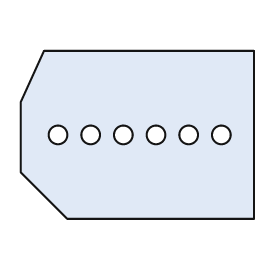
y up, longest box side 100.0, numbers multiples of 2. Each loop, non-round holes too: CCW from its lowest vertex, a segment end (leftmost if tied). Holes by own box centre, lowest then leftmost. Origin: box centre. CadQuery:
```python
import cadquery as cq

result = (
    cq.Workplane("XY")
    .moveTo(-30.0, -36.0)
    .lineTo(50.0, -36.0)
    .lineTo(50.0, 36.0)
    .lineTo(-40.0, 36.0)
    .lineTo(-50.0, 14.0)
    .lineTo(-50.0, -16.0)
    .close()
    .moveTo(-34.0, 0.0)
    .circle(4.0)
    .moveTo(-20.0, 0.0)
    .circle(4.0)
    .moveTo(-6.0, 0.0)
    .circle(4.0)
    .moveTo(8.0, 0.0)
    .circle(4.0)
    .moveTo(22.0, 0.0)
    .circle(4.0)
    .moveTo(36.0, 0.0)
    .circle(4.0)
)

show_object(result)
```